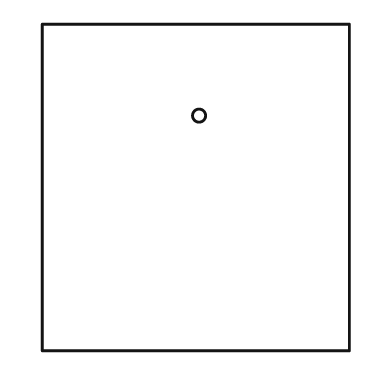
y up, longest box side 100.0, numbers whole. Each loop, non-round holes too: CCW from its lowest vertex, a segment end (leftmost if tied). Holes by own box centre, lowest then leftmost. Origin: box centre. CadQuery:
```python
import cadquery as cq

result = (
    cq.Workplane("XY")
    .moveTo(-47.0, -50.0)
    .lineTo(47.0, -50.0)
    .lineTo(47.0, 50.0)
    .lineTo(-47.0, 50.0)
    .close()
    .moveTo(1.0, 22.0)
    .circle(2.0)
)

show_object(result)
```